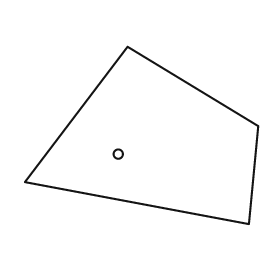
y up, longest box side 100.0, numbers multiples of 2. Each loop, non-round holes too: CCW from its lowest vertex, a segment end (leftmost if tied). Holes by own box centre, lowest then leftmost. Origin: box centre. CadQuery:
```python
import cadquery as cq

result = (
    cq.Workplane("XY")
    .moveTo(46.0, -38.0)
    .lineTo(50.0, 4.0)
    .lineTo(-6.0, 38.0)
    .lineTo(-50.0, -20.0)
    .close()
    .moveTo(-10.0, -8.0)
    .circle(2.0)
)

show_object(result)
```